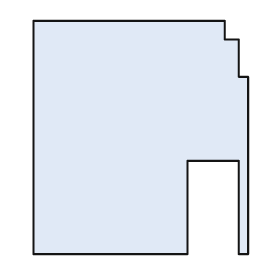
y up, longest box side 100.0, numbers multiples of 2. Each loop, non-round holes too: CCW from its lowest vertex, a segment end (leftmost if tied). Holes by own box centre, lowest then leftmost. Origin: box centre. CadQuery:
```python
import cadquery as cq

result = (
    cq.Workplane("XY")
    .moveTo(-46.0, -50.0)
    .lineTo(20.0, -50.0)
    .lineTo(20.0, -10.0)
    .lineTo(42.0, -10.0)
    .lineTo(42.0, -50.0)
    .lineTo(46.0, -50.0)
    .lineTo(46.0, 26.0)
    .lineTo(42.0, 26.0)
    .lineTo(42.0, 42.0)
    .lineTo(36.0, 42.0)
    .lineTo(36.0, 50.0)
    .lineTo(-46.0, 50.0)
    .close()
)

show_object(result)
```